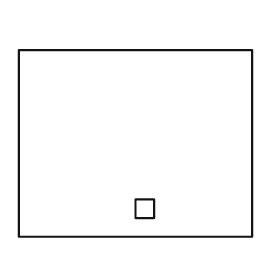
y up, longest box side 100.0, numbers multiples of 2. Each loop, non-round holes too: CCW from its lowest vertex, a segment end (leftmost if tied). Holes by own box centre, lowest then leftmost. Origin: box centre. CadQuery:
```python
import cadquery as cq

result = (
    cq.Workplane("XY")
    .moveTo(-50.0, -40.0)
    .lineTo(50.0, -40.0)
    .lineTo(50.0, 40.0)
    .lineTo(-50.0, 40.0)
    .close()
    .moveTo(0.0, -32.0)
    .lineTo(8.0, -32.0)
    .lineTo(8.0, -24.0)
    .lineTo(0.0, -24.0)
    .close()
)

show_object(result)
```